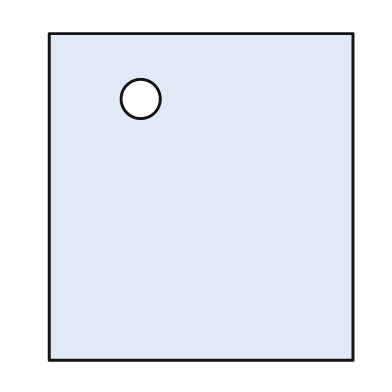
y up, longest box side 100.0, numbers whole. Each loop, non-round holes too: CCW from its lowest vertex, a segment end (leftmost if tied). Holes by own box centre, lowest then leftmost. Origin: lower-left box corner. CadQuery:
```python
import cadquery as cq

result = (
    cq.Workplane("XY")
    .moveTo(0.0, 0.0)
    .lineTo(93.0, 0.0)
    .lineTo(93.0, 100.0)
    .lineTo(0.0, 100.0)
    .close()
    .moveTo(28.0, 80.0)
    .circle(6.0)
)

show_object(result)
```